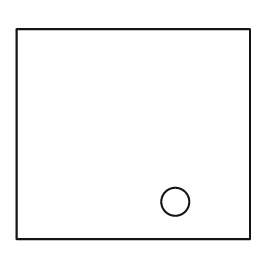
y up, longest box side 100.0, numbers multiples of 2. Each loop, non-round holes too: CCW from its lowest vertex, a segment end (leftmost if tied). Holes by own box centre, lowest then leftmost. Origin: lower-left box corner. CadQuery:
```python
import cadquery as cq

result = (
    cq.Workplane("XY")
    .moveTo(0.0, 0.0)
    .lineTo(100.0, 0.0)
    .lineTo(100.0, 90.0)
    .lineTo(0.0, 90.0)
    .close()
    .moveTo(68.0, 16.0)
    .circle(6.0)
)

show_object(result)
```